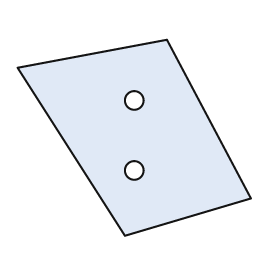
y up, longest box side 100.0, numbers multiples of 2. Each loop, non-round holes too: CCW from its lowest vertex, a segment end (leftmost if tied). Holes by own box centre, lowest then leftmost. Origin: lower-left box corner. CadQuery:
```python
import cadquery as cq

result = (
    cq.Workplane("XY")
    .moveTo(46.0, 0.0)
    .lineTo(100.0, 16.0)
    .lineTo(64.0, 84.0)
    .lineTo(0.0, 72.0)
    .close()
    .moveTo(50.0, 28.0)
    .circle(4.0)
    .moveTo(50.0, 58.0)
    .circle(4.0)
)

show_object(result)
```